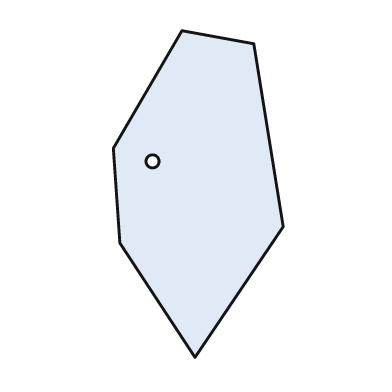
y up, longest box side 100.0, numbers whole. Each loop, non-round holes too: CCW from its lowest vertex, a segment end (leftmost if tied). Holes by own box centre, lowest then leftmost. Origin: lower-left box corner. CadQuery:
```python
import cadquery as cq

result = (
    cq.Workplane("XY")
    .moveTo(25.0, 0.0)
    .lineTo(52.0, 40.0)
    .lineTo(43.0, 96.0)
    .lineTo(21.0, 100.0)
    .lineTo(0.0, 64.0)
    .lineTo(2.0, 35.0)
    .close()
    .moveTo(12.0, 60.0)
    .circle(2.0)
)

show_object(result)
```